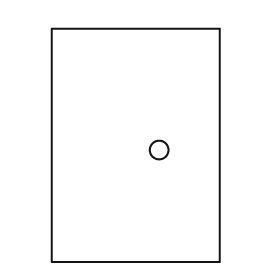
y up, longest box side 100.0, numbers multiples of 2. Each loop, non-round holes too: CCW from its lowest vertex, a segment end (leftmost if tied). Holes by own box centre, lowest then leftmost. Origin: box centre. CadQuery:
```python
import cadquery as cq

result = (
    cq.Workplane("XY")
    .moveTo(-36.0, -50.0)
    .lineTo(36.0, -50.0)
    .lineTo(36.0, 50.0)
    .lineTo(-36.0, 50.0)
    .close()
    .moveTo(10.0, -2.0)
    .circle(4.0)
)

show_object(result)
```